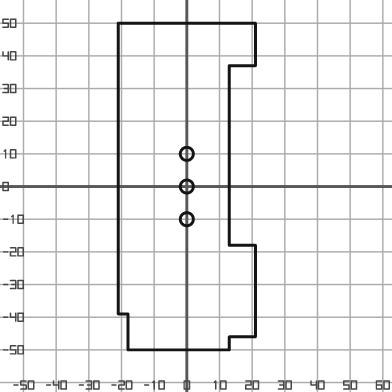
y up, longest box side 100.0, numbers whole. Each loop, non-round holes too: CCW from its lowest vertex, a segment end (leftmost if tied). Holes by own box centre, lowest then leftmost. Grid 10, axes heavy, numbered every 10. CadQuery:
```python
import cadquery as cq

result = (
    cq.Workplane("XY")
    .moveTo(-18.0, -50.0)
    .lineTo(13.0, -50.0)
    .lineTo(13.0, -46.0)
    .lineTo(21.0, -46.0)
    .lineTo(21.0, -18.0)
    .lineTo(13.0, -18.0)
    .lineTo(13.0, 37.0)
    .lineTo(21.0, 37.0)
    .lineTo(21.0, 50.0)
    .lineTo(-21.0, 50.0)
    .lineTo(-21.0, -39.0)
    .lineTo(-18.0, -39.0)
    .close()
    .moveTo(0.0, -10.0)
    .circle(2.0)
    .moveTo(0.0, 0.0)
    .circle(2.0)
    .moveTo(0.0, 10.0)
    .circle(2.0)
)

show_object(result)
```